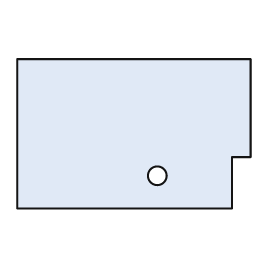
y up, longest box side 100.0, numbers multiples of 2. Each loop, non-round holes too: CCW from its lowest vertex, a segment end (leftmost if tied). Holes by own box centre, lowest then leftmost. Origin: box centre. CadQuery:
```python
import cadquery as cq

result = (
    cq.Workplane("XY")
    .moveTo(-50.0, -32.0)
    .lineTo(42.0, -32.0)
    .lineTo(42.0, -10.0)
    .lineTo(50.0, -10.0)
    .lineTo(50.0, 32.0)
    .lineTo(-50.0, 32.0)
    .close()
    .moveTo(10.0, -18.0)
    .circle(4.0)
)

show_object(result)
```